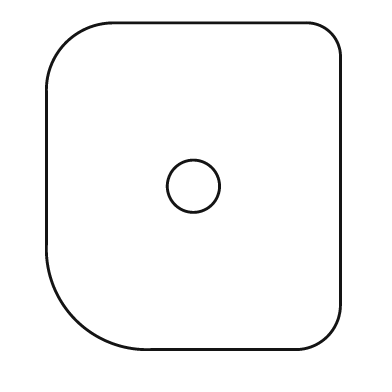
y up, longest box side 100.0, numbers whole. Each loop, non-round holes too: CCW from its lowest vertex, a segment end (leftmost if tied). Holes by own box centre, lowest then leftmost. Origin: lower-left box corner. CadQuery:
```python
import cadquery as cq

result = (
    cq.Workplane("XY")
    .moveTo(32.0, 0.0)
    .lineTo(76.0, 0.0)
    .threePointArc((86.0, 4.0), (90.0, 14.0))
    .lineTo(90.0, 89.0)
    .threePointArc((87.0, 97.0), (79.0, 100.0))
    .lineTo(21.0, 100.0)
    .threePointArc((6.0, 94.0), (0.0, 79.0))
    .lineTo(0.0, 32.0)
    .threePointArc((9.0, 9.0), (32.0, 0.0))
    .close()
    .moveTo(45.0, 50.0)
    .circle(8.0)
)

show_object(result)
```